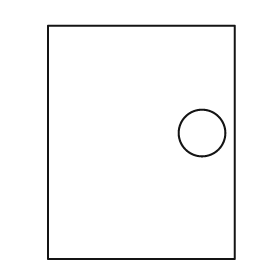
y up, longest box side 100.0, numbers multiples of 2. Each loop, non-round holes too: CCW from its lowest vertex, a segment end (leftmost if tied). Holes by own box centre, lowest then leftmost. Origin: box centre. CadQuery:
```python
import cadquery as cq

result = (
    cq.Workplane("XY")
    .moveTo(-40.0, -50.0)
    .lineTo(40.0, -50.0)
    .lineTo(40.0, 50.0)
    .lineTo(-40.0, 50.0)
    .close()
    .moveTo(26.0, 4.0)
    .circle(10.0)
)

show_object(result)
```